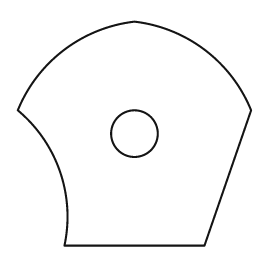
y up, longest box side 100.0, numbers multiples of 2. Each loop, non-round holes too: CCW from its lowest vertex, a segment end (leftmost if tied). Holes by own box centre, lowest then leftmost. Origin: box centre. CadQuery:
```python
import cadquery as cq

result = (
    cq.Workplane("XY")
    .moveTo(-30.0, -48.0)
    .lineTo(30.0, -48.0)
    .lineTo(50.0, 10.0)
    .threePointArc((30.0, 36.0), (0.0, 48.0))
    .threePointArc((-30.0, 36.0), (-50.0, 10.0))
    .threePointArc((-32.0, -16.0), (-30.0, -48.0))
    .close()
    .moveTo(0.0, 0.0)
    .circle(10.0)
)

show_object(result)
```